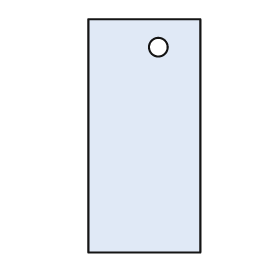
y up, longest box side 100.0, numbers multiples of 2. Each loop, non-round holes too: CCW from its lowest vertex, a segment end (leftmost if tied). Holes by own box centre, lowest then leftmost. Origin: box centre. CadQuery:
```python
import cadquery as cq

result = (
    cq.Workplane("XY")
    .moveTo(-24.0, -50.0)
    .lineTo(24.0, -50.0)
    .lineTo(24.0, 50.0)
    .lineTo(-24.0, 50.0)
    .close()
    .moveTo(6.0, 38.0)
    .circle(4.0)
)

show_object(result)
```